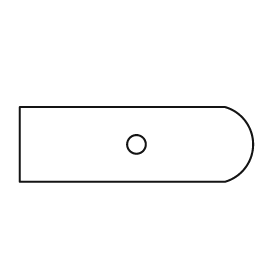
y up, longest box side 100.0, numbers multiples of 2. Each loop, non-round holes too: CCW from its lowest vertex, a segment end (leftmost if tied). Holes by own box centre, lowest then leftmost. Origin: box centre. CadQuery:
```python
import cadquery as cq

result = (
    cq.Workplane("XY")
    .moveTo(-50.0, -16.0)
    .lineTo(38.0, -16.0)
    .threePointArc((50.0, 0.0), (38.0, 16.0))
    .lineTo(-50.0, 16.0)
    .close()
    .moveTo(0.0, 0.0)
    .circle(4.0)
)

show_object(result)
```